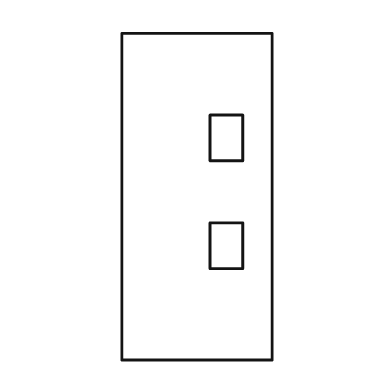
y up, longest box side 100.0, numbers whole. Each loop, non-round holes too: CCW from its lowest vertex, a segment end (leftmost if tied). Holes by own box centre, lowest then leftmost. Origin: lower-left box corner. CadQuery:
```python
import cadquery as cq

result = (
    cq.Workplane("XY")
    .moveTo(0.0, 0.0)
    .lineTo(46.0, 0.0)
    .lineTo(46.0, 100.0)
    .lineTo(0.0, 100.0)
    .close()
    .moveTo(27.0, 28.0)
    .lineTo(37.0, 28.0)
    .lineTo(37.0, 42.0)
    .lineTo(27.0, 42.0)
    .close()
    .moveTo(27.0, 61.0)
    .lineTo(37.0, 61.0)
    .lineTo(37.0, 75.0)
    .lineTo(27.0, 75.0)
    .close()
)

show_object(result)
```